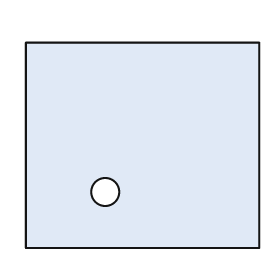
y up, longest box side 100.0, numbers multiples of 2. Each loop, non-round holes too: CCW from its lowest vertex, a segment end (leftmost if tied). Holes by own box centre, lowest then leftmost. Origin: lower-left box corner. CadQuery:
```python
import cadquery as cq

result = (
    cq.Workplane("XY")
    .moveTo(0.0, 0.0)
    .lineTo(100.0, 0.0)
    .lineTo(100.0, 88.0)
    .lineTo(0.0, 88.0)
    .close()
    .moveTo(34.0, 24.0)
    .circle(6.0)
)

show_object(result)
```